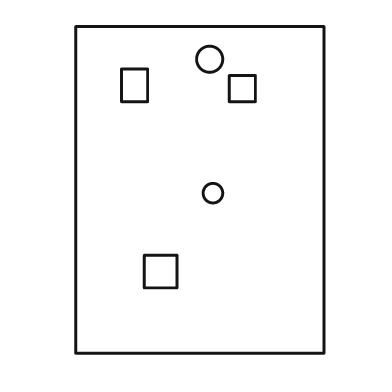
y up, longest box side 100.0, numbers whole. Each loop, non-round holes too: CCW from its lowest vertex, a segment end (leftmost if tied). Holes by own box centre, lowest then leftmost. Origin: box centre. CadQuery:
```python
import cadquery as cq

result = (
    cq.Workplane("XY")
    .moveTo(-38.0, -50.0)
    .lineTo(38.0, -50.0)
    .lineTo(38.0, 50.0)
    .lineTo(-38.0, 50.0)
    .close()
    .moveTo(-17.0, -30.0)
    .lineTo(-7.0, -30.0)
    .lineTo(-7.0, -20.0)
    .lineTo(-17.0, -20.0)
    .close()
    .moveTo(4.0, -1.0)
    .circle(3.0)
    .moveTo(9.0, 27.0)
    .lineTo(17.0, 27.0)
    .lineTo(17.0, 35.0)
    .lineTo(9.0, 35.0)
    .close()
    .moveTo(-24.0, 27.0)
    .lineTo(-16.0, 27.0)
    .lineTo(-16.0, 37.0)
    .lineTo(-24.0, 37.0)
    .close()
    .moveTo(3.0, 40.0)
    .circle(4.0)
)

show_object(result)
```